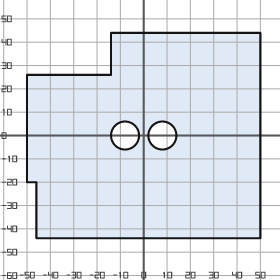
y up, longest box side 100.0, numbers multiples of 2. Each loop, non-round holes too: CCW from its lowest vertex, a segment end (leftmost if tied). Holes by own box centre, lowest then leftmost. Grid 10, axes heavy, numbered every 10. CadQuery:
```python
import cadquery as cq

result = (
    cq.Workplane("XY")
    .moveTo(-46.0, -44.0)
    .lineTo(50.0, -44.0)
    .lineTo(50.0, 44.0)
    .lineTo(-14.0, 44.0)
    .lineTo(-14.0, 26.0)
    .lineTo(-50.0, 26.0)
    .lineTo(-50.0, -20.0)
    .lineTo(-46.0, -20.0)
    .close()
    .moveTo(-8.0, 0.0)
    .circle(6.0)
    .moveTo(8.0, 0.0)
    .circle(6.0)
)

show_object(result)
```